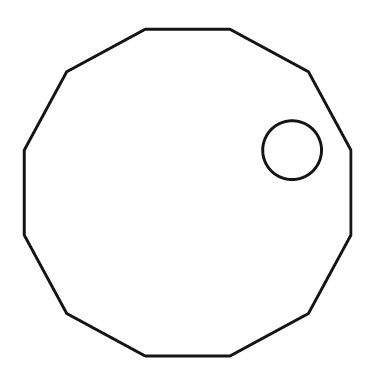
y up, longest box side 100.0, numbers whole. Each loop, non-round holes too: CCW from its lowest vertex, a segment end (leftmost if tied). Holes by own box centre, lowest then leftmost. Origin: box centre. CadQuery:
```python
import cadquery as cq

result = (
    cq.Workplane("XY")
    .moveTo(-13.0, -50.0)
    .lineTo(13.0, -50.0)
    .lineTo(37.0, -37.0)
    .lineTo(50.0, -13.0)
    .lineTo(50.0, 13.0)
    .lineTo(37.0, 37.0)
    .lineTo(13.0, 50.0)
    .lineTo(-13.0, 50.0)
    .lineTo(-37.0, 37.0)
    .lineTo(-50.0, 13.0)
    .lineTo(-50.0, -13.0)
    .lineTo(-37.0, -37.0)
    .close()
    .moveTo(32.0, 13.0)
    .circle(9.0)
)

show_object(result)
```